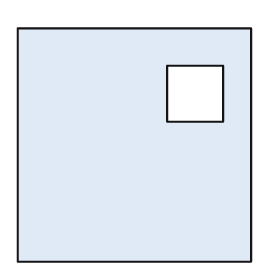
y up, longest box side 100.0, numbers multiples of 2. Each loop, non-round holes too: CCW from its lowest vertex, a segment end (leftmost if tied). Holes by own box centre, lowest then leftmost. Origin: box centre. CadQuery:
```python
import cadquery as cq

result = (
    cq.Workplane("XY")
    .moveTo(-50.0, -50.0)
    .lineTo(50.0, -50.0)
    .lineTo(50.0, 50.0)
    .lineTo(-50.0, 50.0)
    .close()
    .moveTo(14.0, 10.0)
    .lineTo(38.0, 10.0)
    .lineTo(38.0, 34.0)
    .lineTo(14.0, 34.0)
    .close()
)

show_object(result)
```